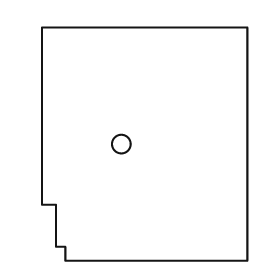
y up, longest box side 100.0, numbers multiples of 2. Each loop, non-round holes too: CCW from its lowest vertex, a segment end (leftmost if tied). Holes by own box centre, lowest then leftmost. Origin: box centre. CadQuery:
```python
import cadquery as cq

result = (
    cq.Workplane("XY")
    .moveTo(-34.0, -50.0)
    .lineTo(44.0, -50.0)
    .lineTo(44.0, 50.0)
    .lineTo(-44.0, 50.0)
    .lineTo(-44.0, -26.0)
    .lineTo(-38.0, -26.0)
    .lineTo(-38.0, -44.0)
    .lineTo(-34.0, -44.0)
    .close()
    .moveTo(-10.0, 0.0)
    .circle(4.0)
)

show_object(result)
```